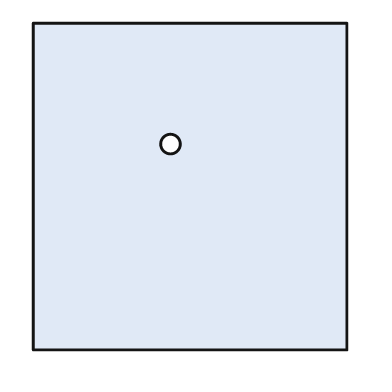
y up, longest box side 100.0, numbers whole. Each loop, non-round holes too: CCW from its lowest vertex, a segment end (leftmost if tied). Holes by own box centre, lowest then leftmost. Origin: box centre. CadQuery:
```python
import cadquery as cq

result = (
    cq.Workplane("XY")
    .moveTo(-48.0, -50.0)
    .lineTo(48.0, -50.0)
    .lineTo(48.0, 50.0)
    .lineTo(-48.0, 50.0)
    .close()
    .moveTo(-6.0, 13.0)
    .circle(3.0)
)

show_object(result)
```